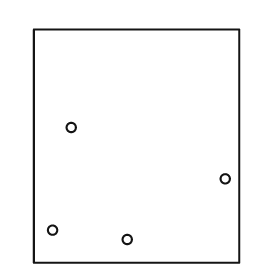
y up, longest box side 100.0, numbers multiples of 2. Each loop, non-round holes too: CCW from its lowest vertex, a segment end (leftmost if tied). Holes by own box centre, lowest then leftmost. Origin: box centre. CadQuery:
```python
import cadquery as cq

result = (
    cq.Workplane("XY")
    .moveTo(-44.0, -50.0)
    .lineTo(44.0, -50.0)
    .lineTo(44.0, 50.0)
    .lineTo(-44.0, 50.0)
    .close()
    .moveTo(-4.0, -40.0)
    .circle(2.0)
    .moveTo(-36.0, -36.0)
    .circle(2.0)
    .moveTo(38.0, -14.0)
    .circle(2.0)
    .moveTo(-28.0, 8.0)
    .circle(2.0)
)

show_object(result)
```